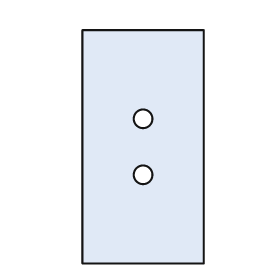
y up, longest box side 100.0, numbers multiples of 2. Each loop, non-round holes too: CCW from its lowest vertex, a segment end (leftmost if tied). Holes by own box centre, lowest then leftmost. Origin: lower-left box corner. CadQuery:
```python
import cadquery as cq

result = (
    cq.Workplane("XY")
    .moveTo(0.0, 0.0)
    .lineTo(52.0, 0.0)
    .lineTo(52.0, 100.0)
    .lineTo(0.0, 100.0)
    .close()
    .moveTo(26.0, 38.0)
    .circle(4.0)
    .moveTo(26.0, 62.0)
    .circle(4.0)
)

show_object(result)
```